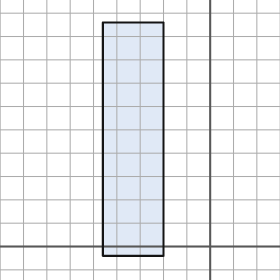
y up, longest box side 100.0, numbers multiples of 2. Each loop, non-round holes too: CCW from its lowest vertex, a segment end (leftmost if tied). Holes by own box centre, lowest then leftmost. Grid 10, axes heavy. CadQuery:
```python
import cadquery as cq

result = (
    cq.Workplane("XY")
    .moveTo(-46.0, -4.0)
    .lineTo(-20.0, -4.0)
    .lineTo(-20.0, 96.0)
    .lineTo(-46.0, 96.0)
    .close()
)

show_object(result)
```